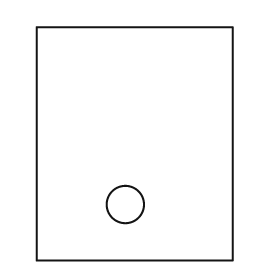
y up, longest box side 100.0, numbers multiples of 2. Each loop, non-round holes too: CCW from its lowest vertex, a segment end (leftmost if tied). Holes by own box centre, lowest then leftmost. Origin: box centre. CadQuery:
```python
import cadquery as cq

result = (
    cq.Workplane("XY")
    .moveTo(-42.0, -50.0)
    .lineTo(42.0, -50.0)
    .lineTo(42.0, 50.0)
    .lineTo(-42.0, 50.0)
    .close()
    .moveTo(-4.0, -26.0)
    .circle(8.0)
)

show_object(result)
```